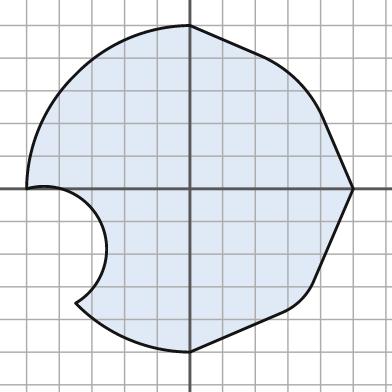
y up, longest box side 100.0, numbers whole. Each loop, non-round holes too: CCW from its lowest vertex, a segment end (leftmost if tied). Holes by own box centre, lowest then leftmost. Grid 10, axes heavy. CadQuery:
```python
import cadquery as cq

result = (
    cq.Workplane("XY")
    .moveTo(0.0, -50.0)
    .lineTo(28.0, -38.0)
    .threePointArc((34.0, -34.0), (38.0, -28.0))
    .lineTo(50.0, 0.0)
    .lineTo(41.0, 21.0)
    .threePointArc((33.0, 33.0), (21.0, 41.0))
    .lineTo(0.0, 50.0)
    .threePointArc((-19.0, 46.0), (-35.0, 35.0))
    .threePointArc((-46.0, 19.0), (-50.0, 0.0))
    .threePointArc((-27.0, -11.0), (-35.0, -35.0))
    .threePointArc((-19.0, -46.0), (0.0, -50.0))
    .close()
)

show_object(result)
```